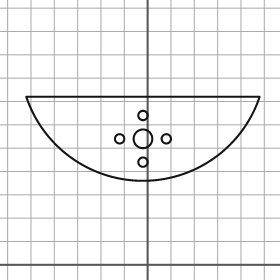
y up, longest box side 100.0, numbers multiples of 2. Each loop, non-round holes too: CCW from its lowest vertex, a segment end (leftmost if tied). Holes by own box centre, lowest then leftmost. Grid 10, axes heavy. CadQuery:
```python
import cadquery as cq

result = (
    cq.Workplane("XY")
    .moveTo(-52.0, 72.0)
    .threePointArc((-2.0, 36.0), (48.0, 72.0))
    .close()
    .moveTo(-2.0, 44.0)
    .circle(2.0)
    .moveTo(-12.0, 54.0)
    .circle(2.0)
    .moveTo(-2.0, 54.0)
    .circle(4.0)
    .moveTo(8.0, 54.0)
    .circle(2.0)
    .moveTo(-2.0, 64.0)
    .circle(2.0)
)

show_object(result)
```